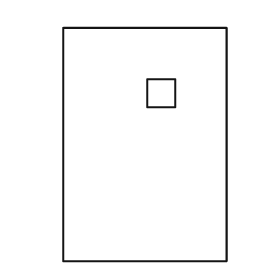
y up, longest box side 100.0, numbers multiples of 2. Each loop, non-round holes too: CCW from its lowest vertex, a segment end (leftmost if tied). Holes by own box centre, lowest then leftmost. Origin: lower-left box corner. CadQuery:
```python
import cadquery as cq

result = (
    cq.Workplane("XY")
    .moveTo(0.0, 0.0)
    .lineTo(70.0, 0.0)
    .lineTo(70.0, 100.0)
    .lineTo(0.0, 100.0)
    .close()
    .moveTo(36.0, 66.0)
    .lineTo(48.0, 66.0)
    .lineTo(48.0, 78.0)
    .lineTo(36.0, 78.0)
    .close()
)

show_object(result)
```